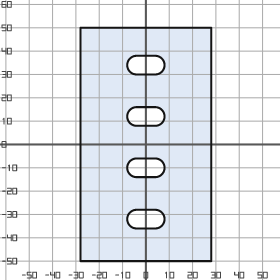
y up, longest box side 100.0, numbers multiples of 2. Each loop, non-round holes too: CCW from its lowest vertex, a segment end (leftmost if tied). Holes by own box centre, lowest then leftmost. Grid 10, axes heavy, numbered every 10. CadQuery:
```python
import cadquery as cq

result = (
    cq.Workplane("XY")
    .moveTo(-28.0, -50.0)
    .lineTo(28.0, -50.0)
    .lineTo(28.0, 50.0)
    .lineTo(-28.0, 50.0)
    .close()
    .moveTo(-4.0, -36.0)
    .lineTo(4.0, -36.0)
    .threePointArc((8.0, -32.0), (4.0, -28.0))
    .lineTo(-4.0, -28.0)
    .threePointArc((-8.0, -32.0), (-4.0, -36.0))
    .close()
    .moveTo(-4.0, -14.0)
    .lineTo(4.0, -14.0)
    .threePointArc((8.0, -10.0), (4.0, -6.0))
    .lineTo(-4.0, -6.0)
    .threePointArc((-8.0, -10.0), (-4.0, -14.0))
    .close()
    .moveTo(-4.0, 8.0)
    .lineTo(4.0, 8.0)
    .threePointArc((8.0, 12.0), (4.0, 16.0))
    .lineTo(-4.0, 16.0)
    .threePointArc((-8.0, 12.0), (-4.0, 8.0))
    .close()
    .moveTo(-4.0, 30.0)
    .lineTo(4.0, 30.0)
    .threePointArc((8.0, 34.0), (4.0, 38.0))
    .lineTo(-4.0, 38.0)
    .threePointArc((-8.0, 34.0), (-4.0, 30.0))
    .close()
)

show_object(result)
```